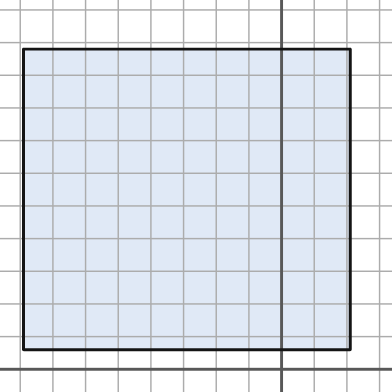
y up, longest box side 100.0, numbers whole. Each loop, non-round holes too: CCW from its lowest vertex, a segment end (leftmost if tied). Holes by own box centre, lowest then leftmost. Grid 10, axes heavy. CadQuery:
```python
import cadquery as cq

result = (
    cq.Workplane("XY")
    .moveTo(-79.0, 6.0)
    .lineTo(21.0, 6.0)
    .lineTo(21.0, 98.0)
    .lineTo(-79.0, 98.0)
    .close()
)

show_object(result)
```